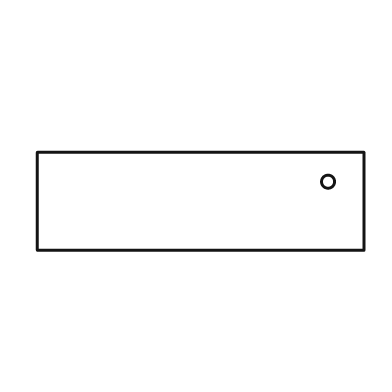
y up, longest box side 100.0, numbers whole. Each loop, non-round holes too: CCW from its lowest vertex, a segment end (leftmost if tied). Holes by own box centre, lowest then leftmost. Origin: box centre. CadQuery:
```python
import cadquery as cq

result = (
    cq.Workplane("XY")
    .moveTo(-50.0, -15.0)
    .lineTo(50.0, -15.0)
    .lineTo(50.0, 15.0)
    .lineTo(-50.0, 15.0)
    .close()
    .moveTo(39.0, 6.0)
    .circle(2.0)
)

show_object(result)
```